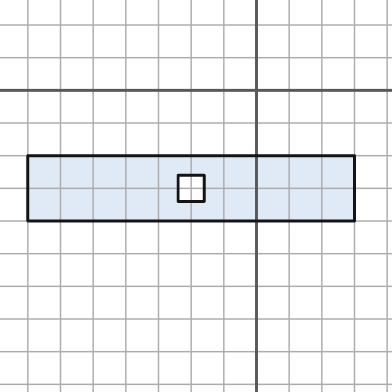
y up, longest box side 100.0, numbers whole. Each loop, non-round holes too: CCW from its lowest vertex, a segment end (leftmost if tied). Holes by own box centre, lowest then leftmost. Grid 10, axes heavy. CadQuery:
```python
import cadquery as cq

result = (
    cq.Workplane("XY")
    .moveTo(-70.0, -40.0)
    .lineTo(30.0, -40.0)
    .lineTo(30.0, -20.0)
    .lineTo(-70.0, -20.0)
    .close()
    .moveTo(-24.0, -34.0)
    .lineTo(-16.0, -34.0)
    .lineTo(-16.0, -26.0)
    .lineTo(-24.0, -26.0)
    .close()
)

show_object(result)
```